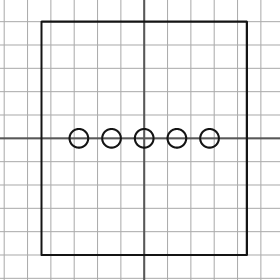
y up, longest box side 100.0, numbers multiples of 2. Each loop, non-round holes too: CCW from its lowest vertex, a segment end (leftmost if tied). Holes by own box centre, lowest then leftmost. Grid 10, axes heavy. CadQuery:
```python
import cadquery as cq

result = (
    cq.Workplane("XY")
    .moveTo(-44.0, -50.0)
    .lineTo(44.0, -50.0)
    .lineTo(44.0, 50.0)
    .lineTo(-44.0, 50.0)
    .close()
    .moveTo(-28.0, 0.0)
    .circle(4.0)
    .moveTo(-14.0, 0.0)
    .circle(4.0)
    .moveTo(0.0, 0.0)
    .circle(4.0)
    .moveTo(14.0, 0.0)
    .circle(4.0)
    .moveTo(28.0, 0.0)
    .circle(4.0)
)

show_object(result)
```